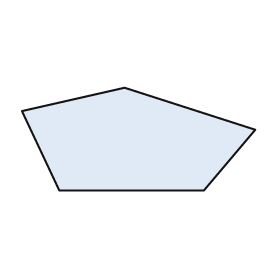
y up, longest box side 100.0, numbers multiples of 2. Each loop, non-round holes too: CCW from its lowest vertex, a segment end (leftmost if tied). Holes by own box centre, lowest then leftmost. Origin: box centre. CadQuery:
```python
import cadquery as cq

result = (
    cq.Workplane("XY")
    .moveTo(-34.0, -22.0)
    .lineTo(28.0, -22.0)
    .lineTo(50.0, 4.0)
    .lineTo(-6.0, 22.0)
    .lineTo(-50.0, 12.0)
    .close()
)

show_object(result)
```